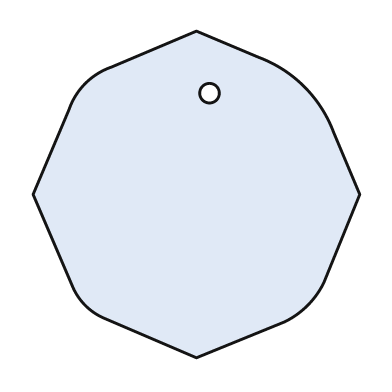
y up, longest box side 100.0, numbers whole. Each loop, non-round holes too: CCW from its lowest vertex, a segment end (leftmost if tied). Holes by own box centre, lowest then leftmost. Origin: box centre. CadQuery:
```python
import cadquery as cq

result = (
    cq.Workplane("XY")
    .moveTo(0.0, -50.0)
    .lineTo(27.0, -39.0)
    .threePointArc((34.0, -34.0), (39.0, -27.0))
    .lineTo(50.0, 0.0)
    .lineTo(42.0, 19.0)
    .threePointArc((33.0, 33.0), (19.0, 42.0))
    .lineTo(0.0, 50.0)
    .lineTo(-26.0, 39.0)
    .threePointArc((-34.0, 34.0), (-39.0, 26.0))
    .lineTo(-50.0, 0.0)
    .lineTo(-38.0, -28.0)
    .threePointArc((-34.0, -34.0), (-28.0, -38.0))
    .close()
    .moveTo(4.0, 31.0)
    .circle(3.0)
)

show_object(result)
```